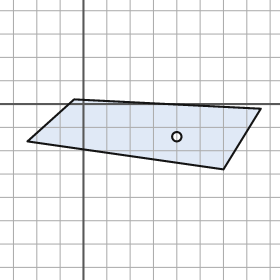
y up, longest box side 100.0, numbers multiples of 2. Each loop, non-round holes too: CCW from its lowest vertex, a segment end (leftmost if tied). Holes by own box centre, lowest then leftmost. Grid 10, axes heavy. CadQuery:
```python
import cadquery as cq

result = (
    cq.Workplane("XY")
    .moveTo(60.0, -28.0)
    .lineTo(76.0, -2.0)
    .lineTo(-4.0, 2.0)
    .lineTo(-24.0, -16.0)
    .close()
    .moveTo(40.0, -14.0)
    .circle(2.0)
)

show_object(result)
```